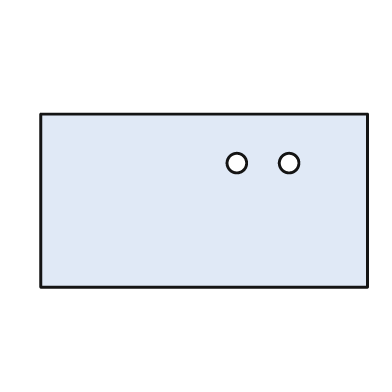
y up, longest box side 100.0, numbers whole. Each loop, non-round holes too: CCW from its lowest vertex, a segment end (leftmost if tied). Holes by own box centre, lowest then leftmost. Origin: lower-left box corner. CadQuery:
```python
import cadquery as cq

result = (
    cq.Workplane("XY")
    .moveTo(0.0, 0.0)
    .lineTo(100.0, 0.0)
    .lineTo(100.0, 53.0)
    .lineTo(0.0, 53.0)
    .close()
    .moveTo(60.0, 38.0)
    .circle(3.0)
    .moveTo(76.0, 38.0)
    .circle(3.0)
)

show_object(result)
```